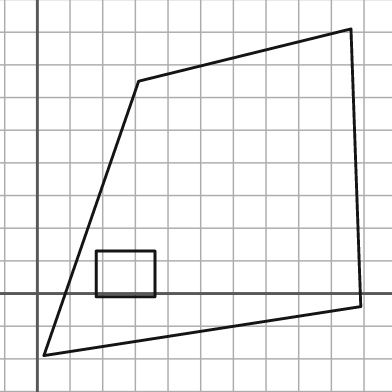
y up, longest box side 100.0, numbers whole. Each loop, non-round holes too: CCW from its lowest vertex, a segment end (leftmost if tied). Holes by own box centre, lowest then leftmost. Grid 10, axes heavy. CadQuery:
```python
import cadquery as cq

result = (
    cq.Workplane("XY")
    .moveTo(2.0, -19.0)
    .lineTo(99.0, -4.0)
    .lineTo(96.0, 81.0)
    .lineTo(31.0, 65.0)
    .close()
    .moveTo(18.0, -1.0)
    .lineTo(36.0, -1.0)
    .lineTo(36.0, 13.0)
    .lineTo(18.0, 13.0)
    .close()
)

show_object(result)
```